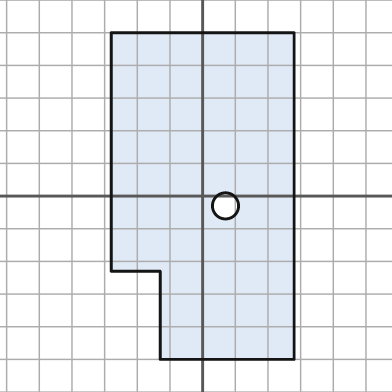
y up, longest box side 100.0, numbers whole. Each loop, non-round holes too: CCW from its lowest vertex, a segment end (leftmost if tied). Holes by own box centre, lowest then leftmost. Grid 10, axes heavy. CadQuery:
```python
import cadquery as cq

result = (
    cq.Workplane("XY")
    .moveTo(-13.0, -50.0)
    .lineTo(28.0, -50.0)
    .lineTo(28.0, 50.0)
    .lineTo(-28.0, 50.0)
    .lineTo(-28.0, -23.0)
    .lineTo(-13.0, -23.0)
    .close()
    .moveTo(7.0, -3.0)
    .circle(4.0)
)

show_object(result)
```